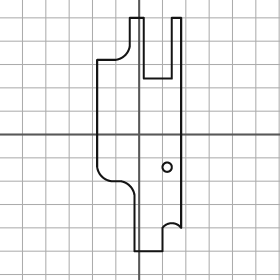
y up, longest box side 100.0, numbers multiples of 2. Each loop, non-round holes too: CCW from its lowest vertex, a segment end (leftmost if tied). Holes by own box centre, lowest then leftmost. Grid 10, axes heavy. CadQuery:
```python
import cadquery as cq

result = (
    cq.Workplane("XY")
    .moveTo(-2.0, -50.0)
    .lineTo(10.0, -50.0)
    .lineTo(10.0, -40.0)
    .threePointArc((14.0, -38.0), (18.0, -40.0))
    .lineTo(18.0, 50.0)
    .lineTo(14.0, 50.0)
    .lineTo(14.0, 24.0)
    .lineTo(2.0, 24.0)
    .lineTo(2.0, 50.0)
    .lineTo(-4.0, 50.0)
    .lineTo(-4.0, 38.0)
    .threePointArc((-6.0, 34.0), (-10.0, 32.0))
    .lineTo(-18.0, 32.0)
    .lineTo(-18.0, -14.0)
    .threePointArc((-16.0, -18.0), (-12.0, -20.0))
    .lineTo(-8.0, -20.0)
    .threePointArc((-4.0, -22.0), (-2.0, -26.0))
    .close()
    .moveTo(12.0, -14.0)
    .circle(2.0)
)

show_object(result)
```